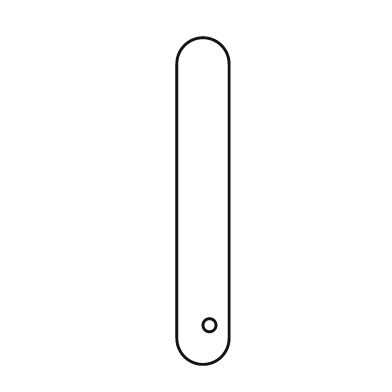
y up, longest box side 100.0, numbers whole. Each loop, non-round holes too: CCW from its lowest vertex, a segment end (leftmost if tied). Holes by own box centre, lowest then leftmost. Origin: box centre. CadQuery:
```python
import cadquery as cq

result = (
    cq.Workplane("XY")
    .moveTo(-8.0, -42.0)
    .threePointArc((0.0, -50.0), (8.0, -42.0))
    .lineTo(8.0, 42.0)
    .threePointArc((0.0, 50.0), (-8.0, 42.0))
    .close()
    .moveTo(2.0, -38.0)
    .circle(2.0)
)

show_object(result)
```